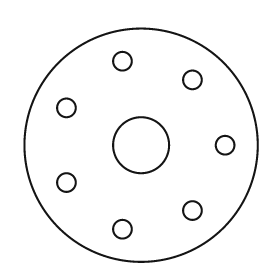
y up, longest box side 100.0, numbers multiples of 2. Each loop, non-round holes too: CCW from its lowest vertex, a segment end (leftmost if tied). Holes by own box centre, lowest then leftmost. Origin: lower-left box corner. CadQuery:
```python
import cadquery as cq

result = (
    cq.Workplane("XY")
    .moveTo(50.0, 50.0)
    .circle(50.0)
    .moveTo(42.0, 14.0)
    .circle(4.0)
    .moveTo(72.0, 22.0)
    .circle(4.0)
    .moveTo(18.0, 34.0)
    .circle(4.0)
    .moveTo(50.0, 50.0)
    .circle(12.0)
    .moveTo(86.0, 50.0)
    .circle(4.0)
    .moveTo(18.0, 66.0)
    .circle(4.0)
    .moveTo(72.0, 78.0)
    .circle(4.0)
    .moveTo(42.0, 86.0)
    .circle(4.0)
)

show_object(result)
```